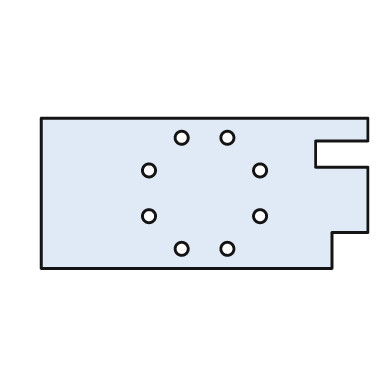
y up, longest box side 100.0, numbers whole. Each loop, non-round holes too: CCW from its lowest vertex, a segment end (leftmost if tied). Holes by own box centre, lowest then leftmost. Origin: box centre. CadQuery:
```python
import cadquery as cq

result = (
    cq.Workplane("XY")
    .moveTo(-50.0, -23.0)
    .lineTo(39.0, -23.0)
    .lineTo(39.0, -12.0)
    .lineTo(50.0, -12.0)
    .lineTo(50.0, 8.0)
    .lineTo(34.0, 8.0)
    .lineTo(34.0, 16.0)
    .lineTo(50.0, 16.0)
    .lineTo(50.0, 23.0)
    .lineTo(-50.0, 23.0)
    .close()
    .moveTo(-7.0, -17.0)
    .circle(2.0)
    .moveTo(7.0, -17.0)
    .circle(2.0)
    .moveTo(-17.0, -7.0)
    .circle(2.0)
    .moveTo(17.0, -7.0)
    .circle(2.0)
    .moveTo(-17.0, 7.0)
    .circle(2.0)
    .moveTo(17.0, 7.0)
    .circle(2.0)
    .moveTo(-7.0, 17.0)
    .circle(2.0)
    .moveTo(7.0, 17.0)
    .circle(2.0)
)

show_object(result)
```